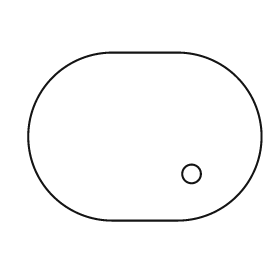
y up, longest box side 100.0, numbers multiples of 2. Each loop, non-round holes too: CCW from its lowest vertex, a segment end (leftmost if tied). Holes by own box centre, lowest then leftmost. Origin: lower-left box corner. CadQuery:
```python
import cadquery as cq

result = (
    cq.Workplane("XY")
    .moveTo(36.0, 0.0)
    .lineTo(64.0, 0.0)
    .threePointArc((100.0, 36.0), (64.0, 72.0))
    .lineTo(36.0, 72.0)
    .threePointArc((0.0, 36.0), (36.0, 0.0))
    .close()
    .moveTo(70.0, 20.0)
    .circle(4.0)
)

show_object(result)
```